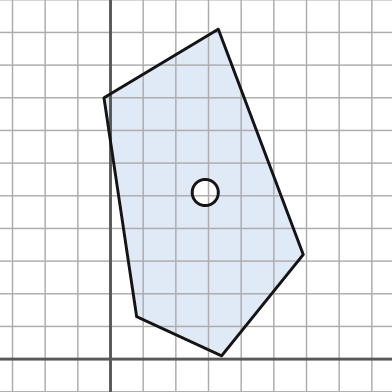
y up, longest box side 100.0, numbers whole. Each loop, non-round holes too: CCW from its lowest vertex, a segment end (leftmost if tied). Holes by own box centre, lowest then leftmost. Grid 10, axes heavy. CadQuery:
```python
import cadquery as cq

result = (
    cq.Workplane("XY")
    .moveTo(34.0, 1.0)
    .lineTo(59.0, 32.0)
    .lineTo(33.0, 101.0)
    .lineTo(-2.0, 80.0)
    .lineTo(8.0, 13.0)
    .close()
    .moveTo(29.0, 51.0)
    .circle(4.0)
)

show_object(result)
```